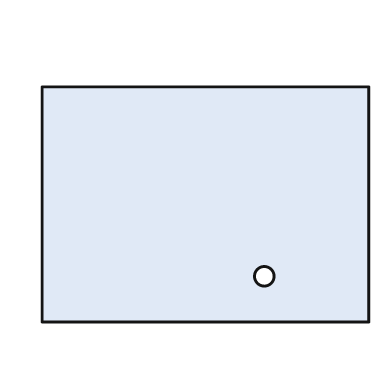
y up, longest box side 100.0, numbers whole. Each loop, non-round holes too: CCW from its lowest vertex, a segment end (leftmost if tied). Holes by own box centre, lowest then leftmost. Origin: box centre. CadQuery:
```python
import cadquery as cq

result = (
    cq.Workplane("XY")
    .moveTo(-50.0, -36.0)
    .lineTo(50.0, -36.0)
    .lineTo(50.0, 36.0)
    .lineTo(-50.0, 36.0)
    .close()
    .moveTo(18.0, -22.0)
    .circle(3.0)
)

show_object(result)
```